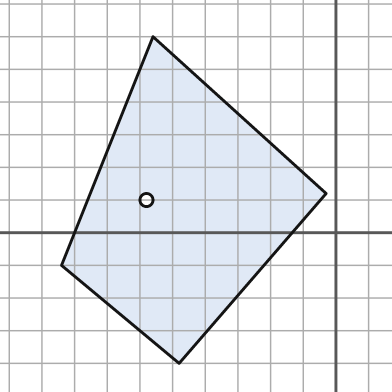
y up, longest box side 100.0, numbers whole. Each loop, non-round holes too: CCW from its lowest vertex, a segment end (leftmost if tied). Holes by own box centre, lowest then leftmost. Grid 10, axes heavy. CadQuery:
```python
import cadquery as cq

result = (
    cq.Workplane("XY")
    .moveTo(-48.0, -40.0)
    .lineTo(-3.0, 12.0)
    .lineTo(-56.0, 60.0)
    .lineTo(-84.0, -10.0)
    .close()
    .moveTo(-58.0, 10.0)
    .circle(2.0)
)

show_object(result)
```